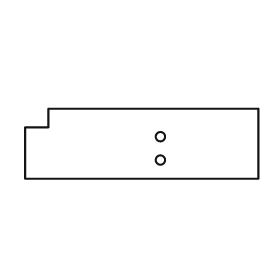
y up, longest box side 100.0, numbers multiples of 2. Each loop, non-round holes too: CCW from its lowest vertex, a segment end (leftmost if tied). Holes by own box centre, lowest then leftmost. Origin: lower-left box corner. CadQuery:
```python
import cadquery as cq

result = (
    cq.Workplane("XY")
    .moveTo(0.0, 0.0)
    .lineTo(100.0, 0.0)
    .lineTo(100.0, 30.0)
    .lineTo(10.0, 30.0)
    .lineTo(10.0, 22.0)
    .lineTo(0.0, 22.0)
    .close()
    .moveTo(58.0, 8.0)
    .circle(2.0)
    .moveTo(58.0, 18.0)
    .circle(2.0)
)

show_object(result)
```